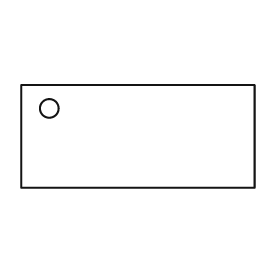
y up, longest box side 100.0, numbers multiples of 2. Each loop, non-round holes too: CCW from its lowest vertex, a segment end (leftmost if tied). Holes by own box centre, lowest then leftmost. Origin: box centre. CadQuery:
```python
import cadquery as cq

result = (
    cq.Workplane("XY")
    .moveTo(-50.0, -22.0)
    .lineTo(50.0, -22.0)
    .lineTo(50.0, 22.0)
    .lineTo(-50.0, 22.0)
    .close()
    .moveTo(-38.0, 12.0)
    .circle(4.0)
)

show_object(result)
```